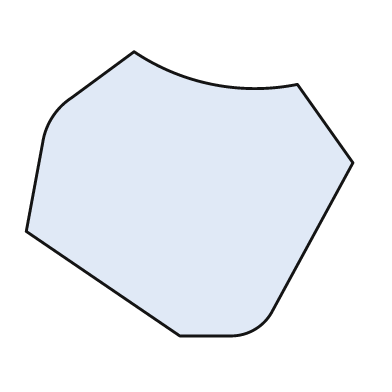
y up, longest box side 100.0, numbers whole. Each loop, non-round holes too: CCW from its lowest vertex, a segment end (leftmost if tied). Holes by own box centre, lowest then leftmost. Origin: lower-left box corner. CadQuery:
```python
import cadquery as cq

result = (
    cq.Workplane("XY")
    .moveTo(47.0, 0.0)
    .lineTo(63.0, 0.0)
    .threePointArc((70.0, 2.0), (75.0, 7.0))
    .lineTo(100.0, 53.0)
    .lineTo(83.0, 77.0)
    .threePointArc((57.0, 77.0), (33.0, 87.0))
    .lineTo(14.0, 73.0)
    .threePointArc((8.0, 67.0), (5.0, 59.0))
    .lineTo(0.0, 32.0)
    .close()
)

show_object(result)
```